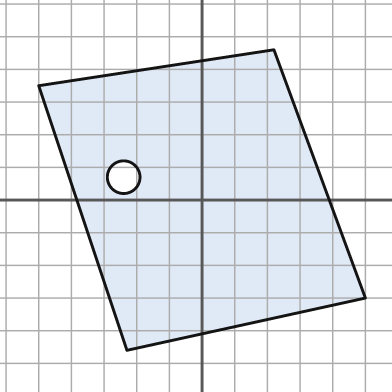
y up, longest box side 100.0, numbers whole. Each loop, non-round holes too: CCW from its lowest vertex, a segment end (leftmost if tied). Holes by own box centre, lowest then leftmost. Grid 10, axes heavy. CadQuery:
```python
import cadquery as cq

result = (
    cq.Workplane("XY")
    .moveTo(-23.0, -46.0)
    .lineTo(50.0, -30.0)
    .lineTo(22.0, 46.0)
    .lineTo(-50.0, 35.0)
    .close()
    .moveTo(-24.0, 7.0)
    .circle(5.0)
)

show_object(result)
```